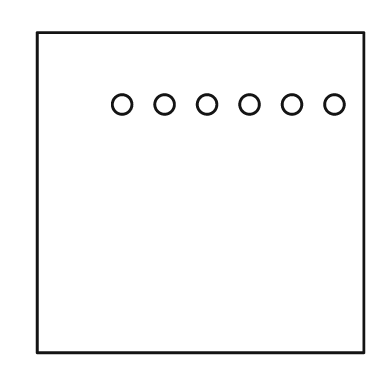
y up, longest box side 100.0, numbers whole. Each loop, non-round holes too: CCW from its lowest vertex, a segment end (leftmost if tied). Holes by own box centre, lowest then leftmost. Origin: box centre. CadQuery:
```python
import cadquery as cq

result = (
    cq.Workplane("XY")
    .moveTo(-50.0, -49.0)
    .lineTo(50.0, -49.0)
    .lineTo(50.0, 49.0)
    .lineTo(-50.0, 49.0)
    .close()
    .moveTo(-24.0, 27.0)
    .circle(3.0)
    .moveTo(-11.0, 27.0)
    .circle(3.0)
    .moveTo(2.0, 27.0)
    .circle(3.0)
    .moveTo(15.0, 27.0)
    .circle(3.0)
    .moveTo(28.0, 27.0)
    .circle(3.0)
    .moveTo(41.0, 27.0)
    .circle(3.0)
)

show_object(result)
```